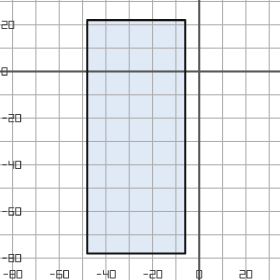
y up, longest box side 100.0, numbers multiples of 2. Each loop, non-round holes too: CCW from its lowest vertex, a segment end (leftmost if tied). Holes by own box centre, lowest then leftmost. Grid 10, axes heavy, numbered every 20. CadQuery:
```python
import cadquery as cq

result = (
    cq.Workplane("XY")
    .moveTo(-48.0, -78.0)
    .lineTo(-6.0, -78.0)
    .lineTo(-6.0, 22.0)
    .lineTo(-48.0, 22.0)
    .close()
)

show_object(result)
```